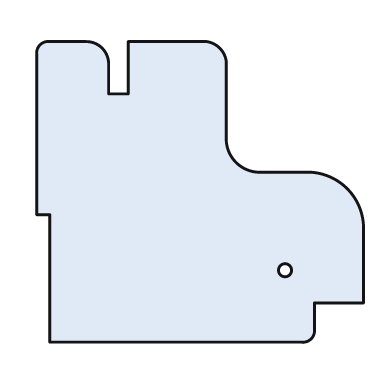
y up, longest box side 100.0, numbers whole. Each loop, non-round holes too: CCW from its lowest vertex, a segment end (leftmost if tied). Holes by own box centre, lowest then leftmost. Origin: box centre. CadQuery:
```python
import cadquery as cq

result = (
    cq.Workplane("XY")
    .moveTo(-46.0, -46.0)
    .lineTo(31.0, -46.0)
    .threePointArc((34.0, -45.0), (35.0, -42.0))
    .lineTo(35.0, -34.0)
    .lineTo(50.0, -34.0)
    .lineTo(50.0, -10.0)
    .threePointArc((45.0, 1.0), (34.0, 6.0))
    .lineTo(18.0, 6.0)
    .threePointArc((11.0, 9.0), (8.0, 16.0))
    .lineTo(8.0, 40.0)
    .threePointArc((6.0, 44.0), (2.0, 46.0))
    .lineTo(-22.0, 46.0)
    .lineTo(-22.0, 30.0)
    .lineTo(-28.0, 30.0)
    .lineTo(-28.0, 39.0)
    .threePointArc((-30.0, 44.0), (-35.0, 46.0))
    .lineTo(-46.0, 46.0)
    .threePointArc((-49.0, 45.0), (-50.0, 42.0))
    .lineTo(-50.0, -7.0)
    .lineTo(-46.0, -7.0)
    .close()
    .moveTo(26.0, -24.0)
    .circle(2.0)
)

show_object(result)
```